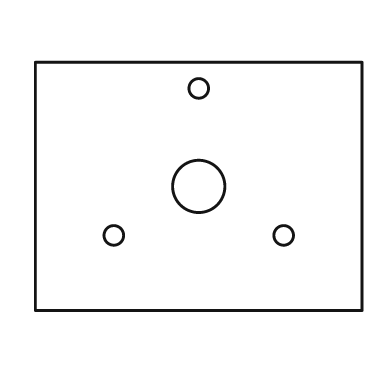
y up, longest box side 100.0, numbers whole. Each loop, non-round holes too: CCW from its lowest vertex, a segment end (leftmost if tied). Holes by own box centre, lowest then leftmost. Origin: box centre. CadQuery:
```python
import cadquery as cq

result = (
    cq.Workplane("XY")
    .moveTo(-50.0, -38.0)
    .lineTo(50.0, -38.0)
    .lineTo(50.0, 38.0)
    .lineTo(-50.0, 38.0)
    .close()
    .moveTo(-26.0, -15.0)
    .circle(3.0)
    .moveTo(26.0, -15.0)
    .circle(3.0)
    .moveTo(0.0, 0.0)
    .circle(8.0)
    .moveTo(0.0, 30.0)
    .circle(3.0)
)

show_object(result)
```